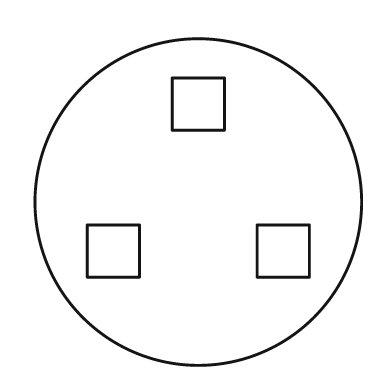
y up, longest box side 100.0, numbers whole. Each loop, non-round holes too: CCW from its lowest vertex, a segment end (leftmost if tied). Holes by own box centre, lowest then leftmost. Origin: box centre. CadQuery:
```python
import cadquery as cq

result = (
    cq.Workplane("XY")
    .moveTo(0.0, 0.0)
    .circle(50.0)
    .moveTo(-34.0, -23.0)
    .lineTo(-18.0, -23.0)
    .lineTo(-18.0, -7.0)
    .lineTo(-34.0, -7.0)
    .close()
    .moveTo(18.0, -23.0)
    .lineTo(34.0, -23.0)
    .lineTo(34.0, -7.0)
    .lineTo(18.0, -7.0)
    .close()
    .moveTo(-8.0, 22.0)
    .lineTo(8.0, 22.0)
    .lineTo(8.0, 38.0)
    .lineTo(-8.0, 38.0)
    .close()
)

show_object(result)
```